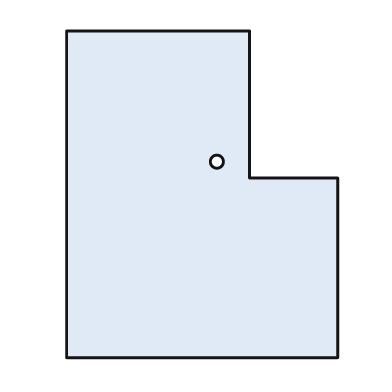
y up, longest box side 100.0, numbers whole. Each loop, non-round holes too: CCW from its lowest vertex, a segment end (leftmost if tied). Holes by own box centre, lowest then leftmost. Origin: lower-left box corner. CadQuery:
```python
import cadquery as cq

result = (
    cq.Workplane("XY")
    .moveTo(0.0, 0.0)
    .lineTo(83.0, 0.0)
    .lineTo(83.0, 55.0)
    .lineTo(56.0, 55.0)
    .lineTo(56.0, 100.0)
    .lineTo(0.0, 100.0)
    .close()
    .moveTo(46.0, 60.0)
    .circle(2.0)
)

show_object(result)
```